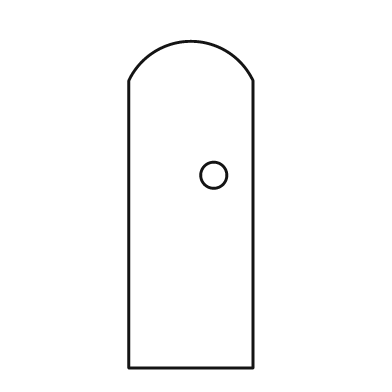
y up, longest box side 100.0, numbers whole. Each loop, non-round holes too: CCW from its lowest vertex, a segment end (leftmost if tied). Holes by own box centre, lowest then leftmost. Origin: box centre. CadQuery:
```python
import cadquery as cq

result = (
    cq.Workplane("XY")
    .moveTo(-19.0, -50.0)
    .lineTo(19.0, -50.0)
    .lineTo(19.0, 38.0)
    .threePointArc((0.0, 50.0), (-19.0, 38.0))
    .close()
    .moveTo(7.0, 9.0)
    .circle(4.0)
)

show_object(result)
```